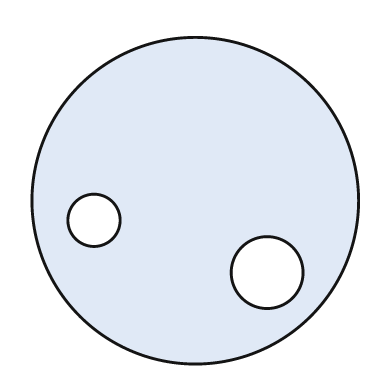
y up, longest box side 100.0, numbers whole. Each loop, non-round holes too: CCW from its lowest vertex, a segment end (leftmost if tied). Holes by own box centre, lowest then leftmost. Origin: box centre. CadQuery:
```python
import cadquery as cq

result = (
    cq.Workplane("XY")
    .moveTo(0.0, 0.0)
    .circle(50.0)
    .moveTo(22.0, -22.0)
    .circle(11.0)
    .moveTo(-31.0, -6.0)
    .circle(8.0)
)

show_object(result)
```